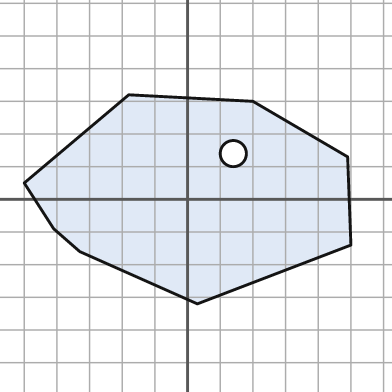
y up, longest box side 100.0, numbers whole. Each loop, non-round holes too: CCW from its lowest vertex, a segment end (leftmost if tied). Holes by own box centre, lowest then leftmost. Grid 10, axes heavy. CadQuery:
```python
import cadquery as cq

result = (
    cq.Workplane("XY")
    .moveTo(3.0, -32.0)
    .lineTo(50.0, -14.0)
    .lineTo(49.0, 13.0)
    .lineTo(20.0, 30.0)
    .lineTo(-18.0, 32.0)
    .lineTo(-50.0, 5.0)
    .lineTo(-41.0, -9.0)
    .lineTo(-33.0, -16.0)
    .close()
    .moveTo(14.0, 14.0)
    .circle(4.0)
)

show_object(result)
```